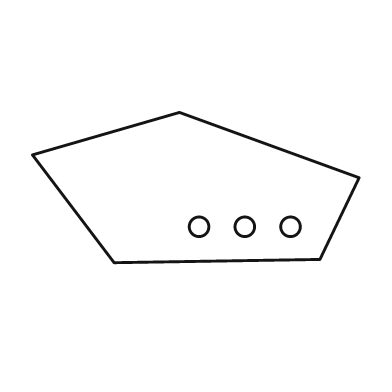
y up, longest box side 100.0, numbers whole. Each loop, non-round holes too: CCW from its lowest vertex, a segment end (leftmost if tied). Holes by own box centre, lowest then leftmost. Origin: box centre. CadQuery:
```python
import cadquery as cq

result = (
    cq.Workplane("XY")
    .moveTo(-25.0, -23.0)
    .lineTo(38.0, -22.0)
    .lineTo(50.0, 3.0)
    .lineTo(-5.0, 23.0)
    .lineTo(-50.0, 10.0)
    .close()
    .moveTo(1.0, -12.0)
    .circle(3.0)
    .moveTo(15.0, -12.0)
    .circle(3.0)
    .moveTo(29.0, -12.0)
    .circle(3.0)
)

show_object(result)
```